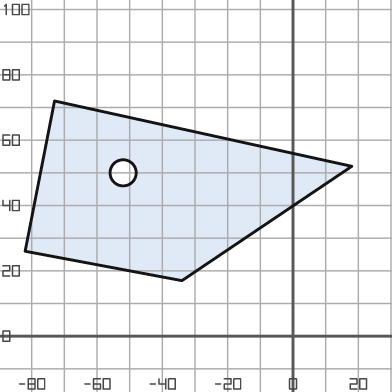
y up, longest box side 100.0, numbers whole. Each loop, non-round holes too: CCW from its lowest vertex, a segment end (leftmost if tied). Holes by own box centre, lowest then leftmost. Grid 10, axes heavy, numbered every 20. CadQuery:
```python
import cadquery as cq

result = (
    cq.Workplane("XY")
    .moveTo(-34.0, 17.0)
    .lineTo(18.0, 52.0)
    .lineTo(-73.0, 72.0)
    .lineTo(-82.0, 26.0)
    .close()
    .moveTo(-52.0, 50.0)
    .circle(4.0)
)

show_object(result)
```